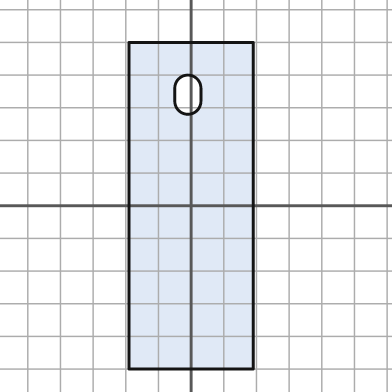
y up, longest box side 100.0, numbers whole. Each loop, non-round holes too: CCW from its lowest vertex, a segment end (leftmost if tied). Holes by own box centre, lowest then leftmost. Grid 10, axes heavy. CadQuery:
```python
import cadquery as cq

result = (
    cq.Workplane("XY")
    .moveTo(-19.0, -50.0)
    .lineTo(19.0, -50.0)
    .lineTo(19.0, 50.0)
    .lineTo(-19.0, 50.0)
    .close()
    .moveTo(-5.0, 32.0)
    .threePointArc((-1.0, 28.0), (3.0, 32.0))
    .lineTo(3.0, 36.0)
    .threePointArc((-1.0, 40.0), (-5.0, 36.0))
    .close()
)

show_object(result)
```